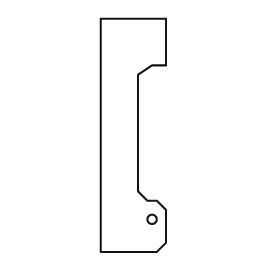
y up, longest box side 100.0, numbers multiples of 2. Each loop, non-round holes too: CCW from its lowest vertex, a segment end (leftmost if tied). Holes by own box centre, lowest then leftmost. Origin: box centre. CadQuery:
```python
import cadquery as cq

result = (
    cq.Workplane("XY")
    .moveTo(-14.0, -50.0)
    .lineTo(10.0, -50.0)
    .lineTo(14.0, -46.0)
    .lineTo(14.0, -32.0)
    .lineTo(10.0, -28.0)
    .lineTo(6.0, -28.0)
    .lineTo(2.0, -24.0)
    .lineTo(2.0, 26.0)
    .lineTo(8.0, 30.0)
    .lineTo(14.0, 30.0)
    .lineTo(14.0, 50.0)
    .lineTo(-14.0, 50.0)
    .close()
    .moveTo(8.0, -36.0)
    .circle(2.0)
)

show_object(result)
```